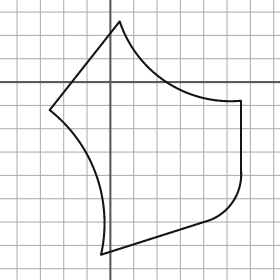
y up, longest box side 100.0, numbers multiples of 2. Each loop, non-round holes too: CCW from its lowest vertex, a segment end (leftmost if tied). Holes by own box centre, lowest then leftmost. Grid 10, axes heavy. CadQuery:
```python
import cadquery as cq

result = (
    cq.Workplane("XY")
    .moveTo(-4.0, -74.0)
    .lineTo(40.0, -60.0)
    .threePointArc((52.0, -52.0), (56.0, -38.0))
    .lineTo(56.0, -8.0)
    .threePointArc((24.0, 0.0), (4.0, 26.0))
    .lineTo(-26.0, -12.0)
    .threePointArc((-6.0, -40.0), (-4.0, -74.0))
    .close()
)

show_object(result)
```